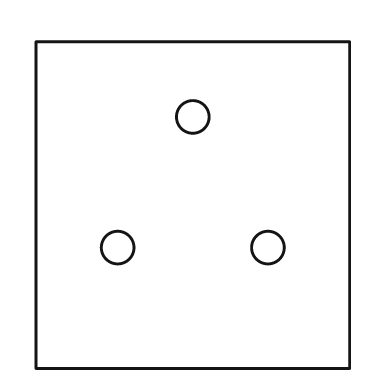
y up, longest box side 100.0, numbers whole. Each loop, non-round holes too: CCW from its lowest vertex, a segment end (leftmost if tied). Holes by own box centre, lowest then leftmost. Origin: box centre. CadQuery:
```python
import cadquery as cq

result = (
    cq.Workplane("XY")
    .moveTo(-48.0, -50.0)
    .lineTo(48.0, -50.0)
    .lineTo(48.0, 50.0)
    .lineTo(-48.0, 50.0)
    .close()
    .moveTo(-23.0, -13.0)
    .circle(5.0)
    .moveTo(23.0, -13.0)
    .circle(5.0)
    .moveTo(0.0, 27.0)
    .circle(5.0)
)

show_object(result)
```